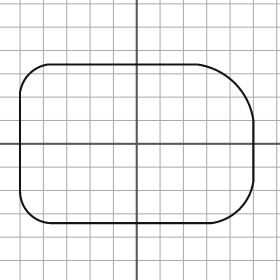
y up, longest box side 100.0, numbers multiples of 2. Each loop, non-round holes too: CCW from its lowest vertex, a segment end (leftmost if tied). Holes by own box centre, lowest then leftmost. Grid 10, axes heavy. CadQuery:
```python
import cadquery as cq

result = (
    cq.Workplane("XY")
    .moveTo(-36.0, -34.0)
    .lineTo(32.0, -34.0)
    .threePointArc((44.0, -28.0), (50.0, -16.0))
    .lineTo(50.0, 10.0)
    .threePointArc((42.0, 26.0), (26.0, 34.0))
    .lineTo(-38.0, 34.0)
    .threePointArc((-46.0, 30.0), (-50.0, 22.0))
    .lineTo(-50.0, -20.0)
    .threePointArc((-46.0, -30.0), (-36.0, -34.0))
    .close()
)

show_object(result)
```